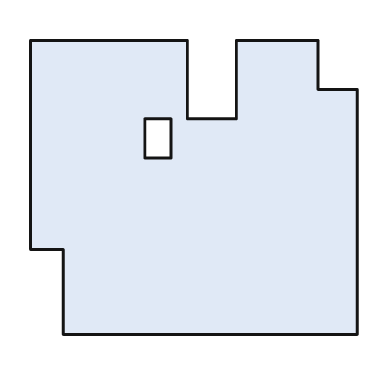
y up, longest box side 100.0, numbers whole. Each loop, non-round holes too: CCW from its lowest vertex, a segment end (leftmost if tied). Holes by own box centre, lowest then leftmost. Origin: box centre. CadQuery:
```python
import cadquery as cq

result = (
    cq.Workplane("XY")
    .moveTo(-40.0, -45.0)
    .lineTo(50.0, -45.0)
    .lineTo(50.0, 30.0)
    .lineTo(38.0, 30.0)
    .lineTo(38.0, 45.0)
    .lineTo(13.0, 45.0)
    .lineTo(13.0, 21.0)
    .lineTo(-2.0, 21.0)
    .lineTo(-2.0, 45.0)
    .lineTo(-50.0, 45.0)
    .lineTo(-50.0, -19.0)
    .lineTo(-40.0, -19.0)
    .close()
    .moveTo(-15.0, 9.0)
    .lineTo(-7.0, 9.0)
    .lineTo(-7.0, 21.0)
    .lineTo(-15.0, 21.0)
    .close()
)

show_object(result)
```